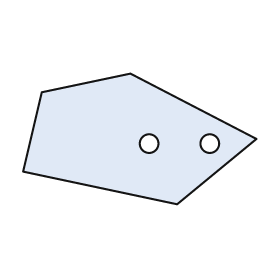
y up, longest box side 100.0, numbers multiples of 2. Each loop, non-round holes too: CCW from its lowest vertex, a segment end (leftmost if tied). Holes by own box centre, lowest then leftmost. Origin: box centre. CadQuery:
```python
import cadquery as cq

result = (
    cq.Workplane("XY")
    .moveTo(16.0, -28.0)
    .lineTo(50.0, 0.0)
    .lineTo(-4.0, 28.0)
    .lineTo(-42.0, 20.0)
    .lineTo(-50.0, -14.0)
    .close()
    .moveTo(4.0, -2.0)
    .circle(4.0)
    .moveTo(30.0, -2.0)
    .circle(4.0)
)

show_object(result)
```